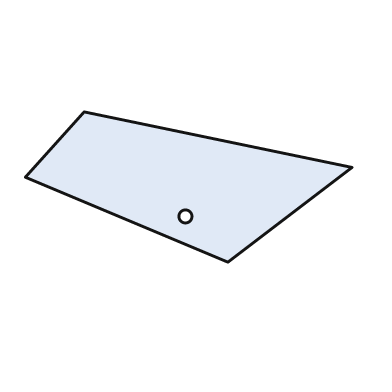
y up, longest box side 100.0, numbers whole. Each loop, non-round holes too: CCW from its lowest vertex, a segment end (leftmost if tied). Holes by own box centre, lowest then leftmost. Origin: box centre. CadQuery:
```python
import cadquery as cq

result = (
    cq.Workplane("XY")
    .moveTo(12.0, -23.0)
    .lineTo(50.0, 6.0)
    .lineTo(-32.0, 23.0)
    .lineTo(-50.0, 3.0)
    .close()
    .moveTo(-1.0, -9.0)
    .circle(2.0)
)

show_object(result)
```